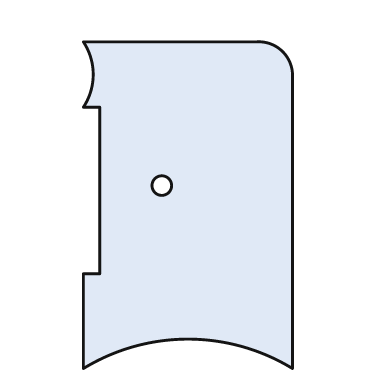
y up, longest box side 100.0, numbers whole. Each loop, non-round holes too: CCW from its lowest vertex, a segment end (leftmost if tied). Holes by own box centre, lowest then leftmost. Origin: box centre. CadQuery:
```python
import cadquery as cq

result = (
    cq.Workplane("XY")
    .moveTo(-32.0, -50.0)
    .threePointArc((0.0, -41.0), (32.0, -50.0))
    .lineTo(32.0, 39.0)
    .threePointArc((29.0, 47.0), (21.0, 50.0))
    .lineTo(-32.0, 50.0)
    .threePointArc((-29.0, 40.0), (-32.0, 30.0))
    .lineTo(-27.0, 30.0)
    .lineTo(-27.0, -21.0)
    .lineTo(-32.0, -21.0)
    .close()
    .moveTo(-8.0, 6.0)
    .circle(3.0)
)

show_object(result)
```